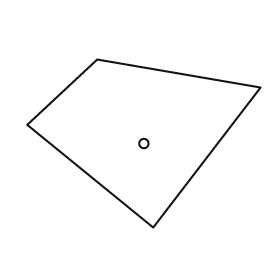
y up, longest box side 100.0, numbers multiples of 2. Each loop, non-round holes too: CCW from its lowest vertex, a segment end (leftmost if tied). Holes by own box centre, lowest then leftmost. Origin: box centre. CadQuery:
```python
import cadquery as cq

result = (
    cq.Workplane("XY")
    .moveTo(4.0, -36.0)
    .lineTo(50.0, 24.0)
    .lineTo(-20.0, 36.0)
    .lineTo(-50.0, 8.0)
    .close()
    .moveTo(0.0, 0.0)
    .circle(2.0)
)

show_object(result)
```